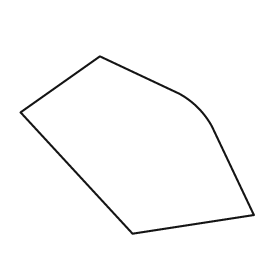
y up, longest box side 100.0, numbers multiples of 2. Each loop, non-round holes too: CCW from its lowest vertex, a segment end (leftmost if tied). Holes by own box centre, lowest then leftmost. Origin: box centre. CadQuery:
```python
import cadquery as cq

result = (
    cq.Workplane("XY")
    .moveTo(-2.0, -38.0)
    .lineTo(50.0, -30.0)
    .lineTo(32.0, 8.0)
    .threePointArc((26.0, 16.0), (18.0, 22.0))
    .lineTo(-16.0, 38.0)
    .lineTo(-50.0, 14.0)
    .close()
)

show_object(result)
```